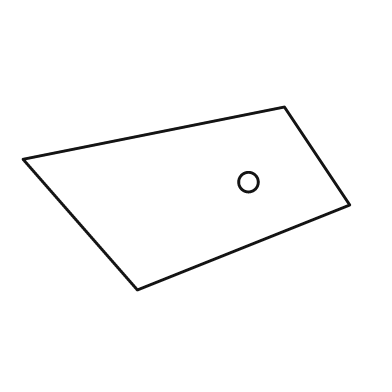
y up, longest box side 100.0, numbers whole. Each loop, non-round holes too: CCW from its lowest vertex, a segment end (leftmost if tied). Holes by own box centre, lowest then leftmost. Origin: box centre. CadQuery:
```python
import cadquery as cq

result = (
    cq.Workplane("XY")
    .moveTo(-15.0, -28.0)
    .lineTo(50.0, -2.0)
    .lineTo(30.0, 28.0)
    .lineTo(-50.0, 12.0)
    .close()
    .moveTo(19.0, 5.0)
    .circle(3.0)
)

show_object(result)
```